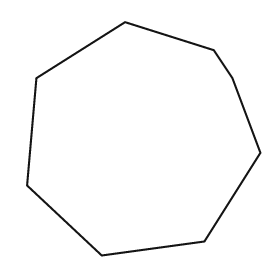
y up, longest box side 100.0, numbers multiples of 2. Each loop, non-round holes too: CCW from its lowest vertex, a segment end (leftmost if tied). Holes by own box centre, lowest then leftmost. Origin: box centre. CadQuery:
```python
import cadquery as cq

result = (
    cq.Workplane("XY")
    .moveTo(-18.0, -50.0)
    .lineTo(26.0, -44.0)
    .lineTo(50.0, -6.0)
    .lineTo(38.0, 26.0)
    .lineTo(30.0, 38.0)
    .lineTo(-8.0, 50.0)
    .lineTo(-46.0, 26.0)
    .lineTo(-50.0, -20.0)
    .close()
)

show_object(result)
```